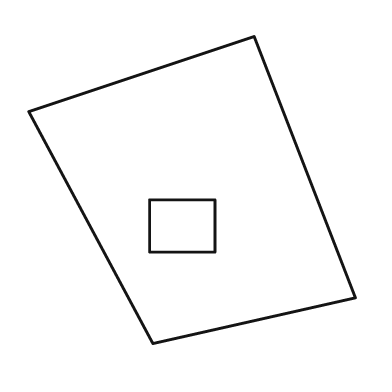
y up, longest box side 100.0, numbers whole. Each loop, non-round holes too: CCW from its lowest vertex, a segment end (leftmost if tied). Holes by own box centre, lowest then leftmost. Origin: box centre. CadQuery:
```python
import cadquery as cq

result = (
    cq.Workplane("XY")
    .moveTo(-12.0, -47.0)
    .lineTo(50.0, -33.0)
    .lineTo(19.0, 47.0)
    .lineTo(-50.0, 24.0)
    .close()
    .moveTo(-13.0, -19.0)
    .lineTo(7.0, -19.0)
    .lineTo(7.0, -3.0)
    .lineTo(-13.0, -3.0)
    .close()
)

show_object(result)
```